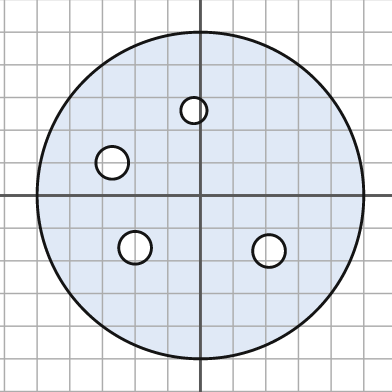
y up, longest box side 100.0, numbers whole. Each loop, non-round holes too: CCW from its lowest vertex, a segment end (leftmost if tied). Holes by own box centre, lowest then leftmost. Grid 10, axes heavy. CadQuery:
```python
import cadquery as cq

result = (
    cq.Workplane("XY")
    .moveTo(0.0, 0.0)
    .circle(50.0)
    .moveTo(21.0, -17.0)
    .circle(5.0)
    .moveTo(-20.0, -16.0)
    .circle(5.0)
    .moveTo(-27.0, 10.0)
    .circle(5.0)
    .moveTo(-2.0, 26.0)
    .circle(4.0)
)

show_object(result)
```